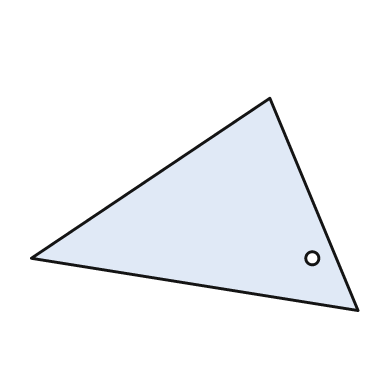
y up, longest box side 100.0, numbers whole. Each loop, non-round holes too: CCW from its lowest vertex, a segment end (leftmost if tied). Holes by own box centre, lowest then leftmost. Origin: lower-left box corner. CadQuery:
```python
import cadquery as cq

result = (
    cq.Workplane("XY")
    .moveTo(100.0, 0.0)
    .lineTo(73.0, 65.0)
    .lineTo(0.0, 16.0)
    .close()
    .moveTo(86.0, 16.0)
    .circle(2.0)
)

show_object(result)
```